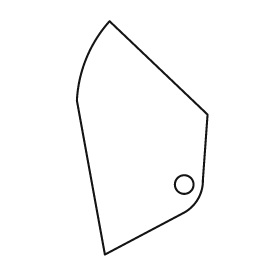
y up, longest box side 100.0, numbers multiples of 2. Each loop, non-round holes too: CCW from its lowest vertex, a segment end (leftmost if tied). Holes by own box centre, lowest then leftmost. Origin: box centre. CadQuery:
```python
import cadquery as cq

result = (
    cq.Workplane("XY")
    .moveTo(-16.0, -50.0)
    .lineTo(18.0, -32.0)
    .threePointArc((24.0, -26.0), (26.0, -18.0))
    .lineTo(28.0, 10.0)
    .lineTo(-14.0, 50.0)
    .threePointArc((-24.0, 34.0), (-28.0, 16.0))
    .close()
    .moveTo(18.0, -20.0)
    .circle(4.0)
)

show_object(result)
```